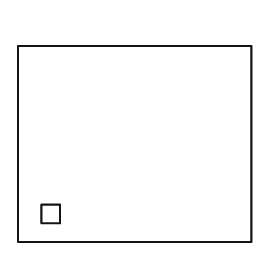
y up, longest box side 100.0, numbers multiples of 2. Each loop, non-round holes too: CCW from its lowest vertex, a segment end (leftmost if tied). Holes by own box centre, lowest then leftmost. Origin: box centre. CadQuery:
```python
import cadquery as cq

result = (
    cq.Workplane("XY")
    .moveTo(-50.0, -42.0)
    .lineTo(50.0, -42.0)
    .lineTo(50.0, 42.0)
    .lineTo(-50.0, 42.0)
    .close()
    .moveTo(-40.0, -34.0)
    .lineTo(-32.0, -34.0)
    .lineTo(-32.0, -26.0)
    .lineTo(-40.0, -26.0)
    .close()
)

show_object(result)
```